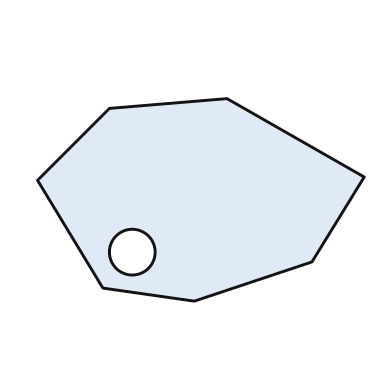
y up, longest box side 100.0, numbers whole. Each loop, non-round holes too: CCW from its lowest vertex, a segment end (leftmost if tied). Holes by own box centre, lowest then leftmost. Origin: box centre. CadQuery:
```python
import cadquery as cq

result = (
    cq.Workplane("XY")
    .moveTo(-2.0, -31.0)
    .lineTo(34.0, -19.0)
    .lineTo(50.0, 7.0)
    .lineTo(8.0, 31.0)
    .lineTo(-28.0, 28.0)
    .lineTo(-50.0, 6.0)
    .lineTo(-30.0, -27.0)
    .close()
    .moveTo(-21.0, -16.0)
    .circle(7.0)
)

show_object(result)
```